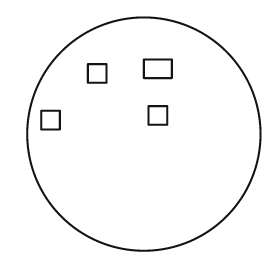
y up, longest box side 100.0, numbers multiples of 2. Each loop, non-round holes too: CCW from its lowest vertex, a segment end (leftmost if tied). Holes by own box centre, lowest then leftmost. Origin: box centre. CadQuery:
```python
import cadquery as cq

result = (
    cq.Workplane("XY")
    .moveTo(0.0, 0.0)
    .circle(50.0)
    .moveTo(-44.0, 2.0)
    .lineTo(-36.0, 2.0)
    .lineTo(-36.0, 10.0)
    .lineTo(-44.0, 10.0)
    .close()
    .moveTo(2.0, 4.0)
    .lineTo(10.0, 4.0)
    .lineTo(10.0, 12.0)
    .lineTo(2.0, 12.0)
    .close()
    .moveTo(-24.0, 22.0)
    .lineTo(-16.0, 22.0)
    .lineTo(-16.0, 30.0)
    .lineTo(-24.0, 30.0)
    .close()
    .moveTo(0.0, 24.0)
    .lineTo(12.0, 24.0)
    .lineTo(12.0, 32.0)
    .lineTo(0.0, 32.0)
    .close()
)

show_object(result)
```